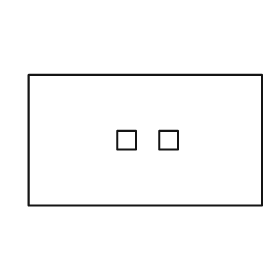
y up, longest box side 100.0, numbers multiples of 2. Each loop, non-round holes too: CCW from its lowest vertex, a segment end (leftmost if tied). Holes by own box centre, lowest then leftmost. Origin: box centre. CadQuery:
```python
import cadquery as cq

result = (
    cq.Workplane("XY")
    .moveTo(-50.0, -28.0)
    .lineTo(50.0, -28.0)
    .lineTo(50.0, 28.0)
    .lineTo(-50.0, 28.0)
    .close()
    .moveTo(-12.0, -4.0)
    .lineTo(-4.0, -4.0)
    .lineTo(-4.0, 4.0)
    .lineTo(-12.0, 4.0)
    .close()
    .moveTo(6.0, -4.0)
    .lineTo(14.0, -4.0)
    .lineTo(14.0, 4.0)
    .lineTo(6.0, 4.0)
    .close()
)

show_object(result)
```